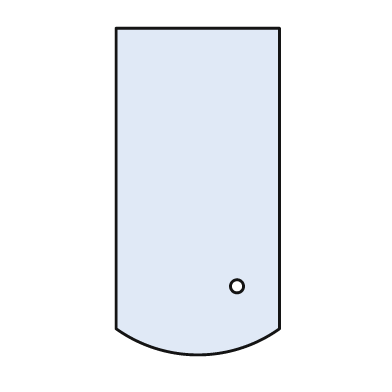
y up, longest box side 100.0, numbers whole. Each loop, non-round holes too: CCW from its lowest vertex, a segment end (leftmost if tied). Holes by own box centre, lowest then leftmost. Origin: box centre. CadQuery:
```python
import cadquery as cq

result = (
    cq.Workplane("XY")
    .moveTo(-25.0, -42.0)
    .threePointArc((0.0, -50.0), (25.0, -42.0))
    .lineTo(25.0, 50.0)
    .lineTo(-25.0, 50.0)
    .close()
    .moveTo(12.0, -29.0)
    .circle(2.0)
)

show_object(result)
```